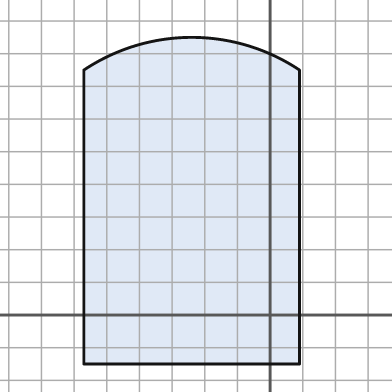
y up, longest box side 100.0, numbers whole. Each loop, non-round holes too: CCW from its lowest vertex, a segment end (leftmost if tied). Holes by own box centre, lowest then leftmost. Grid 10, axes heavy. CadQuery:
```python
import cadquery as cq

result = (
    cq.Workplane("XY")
    .moveTo(-57.0, -15.0)
    .lineTo(9.0, -15.0)
    .lineTo(9.0, 75.0)
    .threePointArc((-24.0, 85.0), (-57.0, 75.0))
    .close()
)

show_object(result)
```